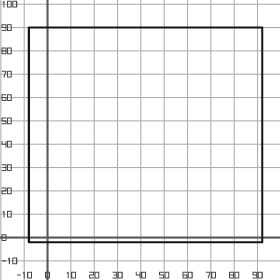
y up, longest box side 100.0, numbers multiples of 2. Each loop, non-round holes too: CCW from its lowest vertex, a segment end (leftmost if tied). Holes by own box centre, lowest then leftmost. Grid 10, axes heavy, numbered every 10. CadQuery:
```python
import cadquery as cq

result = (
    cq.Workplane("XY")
    .moveTo(-8.0, -2.0)
    .lineTo(92.0, -2.0)
    .lineTo(92.0, 90.0)
    .lineTo(-8.0, 90.0)
    .close()
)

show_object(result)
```